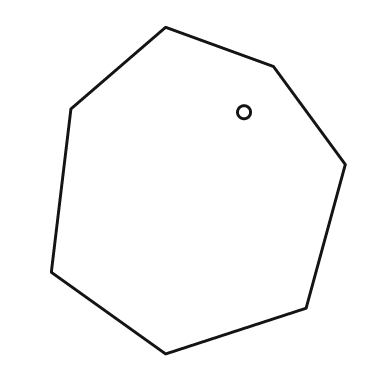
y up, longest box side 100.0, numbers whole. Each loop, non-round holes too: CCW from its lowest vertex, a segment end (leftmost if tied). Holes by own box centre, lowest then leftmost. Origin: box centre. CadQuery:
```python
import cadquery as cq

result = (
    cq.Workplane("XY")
    .moveTo(-10.0, -50.0)
    .lineTo(33.0, -36.0)
    .lineTo(45.0, 8.0)
    .lineTo(23.0, 38.0)
    .lineTo(-10.0, 50.0)
    .lineTo(-39.0, 25.0)
    .lineTo(-45.0, -25.0)
    .close()
    .moveTo(14.0, 24.0)
    .circle(2.0)
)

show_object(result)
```